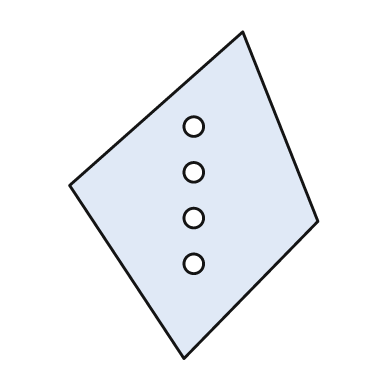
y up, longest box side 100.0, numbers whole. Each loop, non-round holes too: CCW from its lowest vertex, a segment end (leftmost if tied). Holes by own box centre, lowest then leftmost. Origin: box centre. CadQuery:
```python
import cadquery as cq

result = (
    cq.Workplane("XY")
    .moveTo(-3.0, -50.0)
    .lineTo(38.0, -8.0)
    .lineTo(15.0, 50.0)
    .lineTo(-38.0, 3.0)
    .close()
    .moveTo(0.0, -21.0)
    .circle(3.0)
    .moveTo(0.0, -7.0)
    .circle(3.0)
    .moveTo(0.0, 7.0)
    .circle(3.0)
    .moveTo(0.0, 21.0)
    .circle(3.0)
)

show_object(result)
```